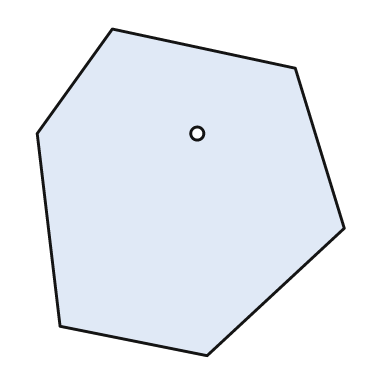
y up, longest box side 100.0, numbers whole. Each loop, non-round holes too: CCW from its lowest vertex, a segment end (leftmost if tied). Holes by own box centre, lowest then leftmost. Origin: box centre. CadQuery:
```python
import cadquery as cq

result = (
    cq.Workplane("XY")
    .moveTo(5.0, -50.0)
    .lineTo(47.0, -11.0)
    .lineTo(32.0, 38.0)
    .lineTo(-24.0, 50.0)
    .lineTo(-47.0, 18.0)
    .lineTo(-40.0, -41.0)
    .close()
    .moveTo(2.0, 18.0)
    .circle(2.0)
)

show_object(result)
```